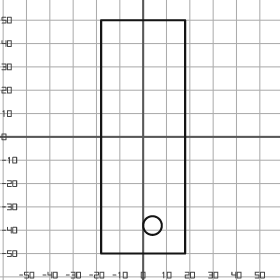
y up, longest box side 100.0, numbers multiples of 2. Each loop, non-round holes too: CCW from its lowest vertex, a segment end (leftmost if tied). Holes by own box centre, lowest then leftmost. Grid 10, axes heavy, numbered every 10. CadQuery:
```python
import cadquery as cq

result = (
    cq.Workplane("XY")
    .moveTo(-18.0, -50.0)
    .lineTo(18.0, -50.0)
    .lineTo(18.0, 50.0)
    .lineTo(-18.0, 50.0)
    .close()
    .moveTo(4.0, -38.0)
    .circle(4.0)
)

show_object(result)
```